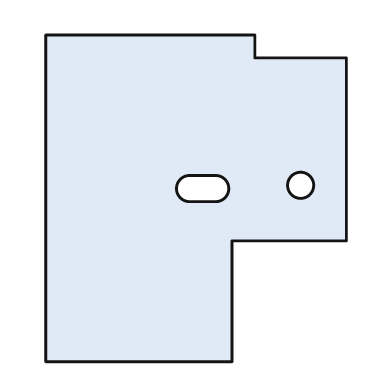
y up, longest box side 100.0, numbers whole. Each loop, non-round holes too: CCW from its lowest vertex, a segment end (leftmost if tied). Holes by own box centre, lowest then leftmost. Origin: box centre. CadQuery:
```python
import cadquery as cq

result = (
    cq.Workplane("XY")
    .moveTo(-46.0, -50.0)
    .lineTo(11.0, -50.0)
    .lineTo(11.0, -13.0)
    .lineTo(46.0, -13.0)
    .lineTo(46.0, 43.0)
    .lineTo(18.0, 43.0)
    .lineTo(18.0, 50.0)
    .lineTo(-46.0, 50.0)
    .close()
    .moveTo(-2.0, -1.0)
    .lineTo(6.0, -1.0)
    .threePointArc((10.0, 3.0), (6.0, 7.0))
    .lineTo(-2.0, 7.0)
    .threePointArc((-6.0, 3.0), (-2.0, -1.0))
    .close()
    .moveTo(32.0, 4.0)
    .circle(4.0)
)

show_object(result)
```